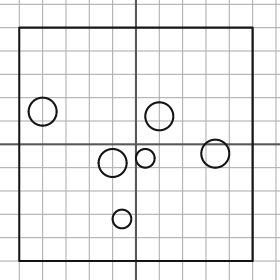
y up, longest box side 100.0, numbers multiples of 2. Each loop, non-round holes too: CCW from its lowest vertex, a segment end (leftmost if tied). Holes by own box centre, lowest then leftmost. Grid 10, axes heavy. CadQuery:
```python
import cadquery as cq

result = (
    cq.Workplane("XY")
    .moveTo(-50.0, -50.0)
    .lineTo(50.0, -50.0)
    .lineTo(50.0, 50.0)
    .lineTo(-50.0, 50.0)
    .close()
    .moveTo(-6.0, -32.0)
    .circle(4.0)
    .moveTo(-10.0, -8.0)
    .circle(6.0)
    .moveTo(4.0, -6.0)
    .circle(4.0)
    .moveTo(34.0, -4.0)
    .circle(6.0)
    .moveTo(10.0, 12.0)
    .circle(6.0)
    .moveTo(-40.0, 14.0)
    .circle(6.0)
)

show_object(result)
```